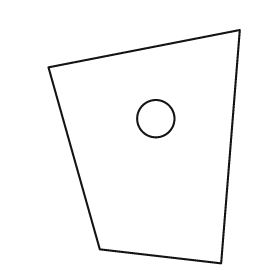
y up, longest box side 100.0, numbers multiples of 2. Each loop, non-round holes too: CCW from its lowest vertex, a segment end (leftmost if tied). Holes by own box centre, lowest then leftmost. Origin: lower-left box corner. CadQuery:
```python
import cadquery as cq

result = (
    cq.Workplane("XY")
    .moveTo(74.0, 0.0)
    .lineTo(82.0, 100.0)
    .lineTo(0.0, 84.0)
    .lineTo(22.0, 6.0)
    .close()
    .moveTo(46.0, 62.0)
    .circle(8.0)
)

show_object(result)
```